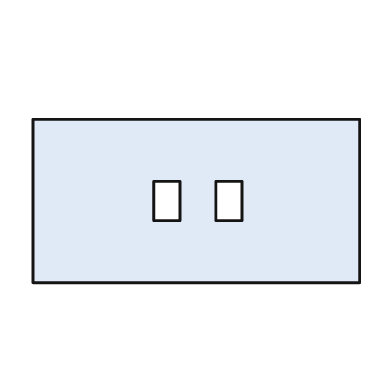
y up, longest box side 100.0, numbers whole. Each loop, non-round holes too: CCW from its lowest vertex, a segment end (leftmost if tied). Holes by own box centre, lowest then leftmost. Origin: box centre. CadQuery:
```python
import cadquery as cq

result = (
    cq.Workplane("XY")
    .moveTo(-50.0, -25.0)
    .lineTo(50.0, -25.0)
    .lineTo(50.0, 25.0)
    .lineTo(-50.0, 25.0)
    .close()
    .moveTo(-13.0, -6.0)
    .lineTo(-5.0, -6.0)
    .lineTo(-5.0, 6.0)
    .lineTo(-13.0, 6.0)
    .close()
    .moveTo(6.0, -6.0)
    .lineTo(14.0, -6.0)
    .lineTo(14.0, 6.0)
    .lineTo(6.0, 6.0)
    .close()
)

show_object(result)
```